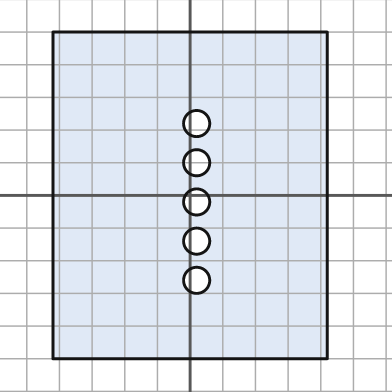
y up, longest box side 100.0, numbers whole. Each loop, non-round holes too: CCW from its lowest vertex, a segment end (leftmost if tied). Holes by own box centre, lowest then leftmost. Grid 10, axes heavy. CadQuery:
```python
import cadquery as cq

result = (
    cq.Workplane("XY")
    .moveTo(-42.0, -50.0)
    .lineTo(42.0, -50.0)
    .lineTo(42.0, 50.0)
    .lineTo(-42.0, 50.0)
    .close()
    .moveTo(2.0, -26.0)
    .circle(4.0)
    .moveTo(2.0, -14.0)
    .circle(4.0)
    .moveTo(2.0, -2.0)
    .circle(4.0)
    .moveTo(2.0, 10.0)
    .circle(4.0)
    .moveTo(2.0, 22.0)
    .circle(4.0)
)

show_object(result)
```